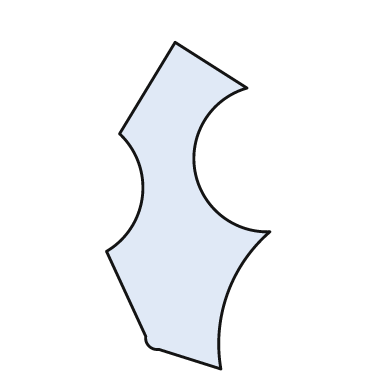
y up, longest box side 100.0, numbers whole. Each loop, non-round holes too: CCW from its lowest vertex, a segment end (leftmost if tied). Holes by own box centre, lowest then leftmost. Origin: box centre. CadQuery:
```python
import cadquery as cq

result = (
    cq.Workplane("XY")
    .moveTo(10.0, -50.0)
    .threePointArc((12.0, -27.0), (25.0, -8.0))
    .threePointArc((2.0, 11.0), (18.0, 36.0))
    .lineTo(-4.0, 50.0)
    .lineTo(-21.0, 22.0)
    .threePointArc((-14.0, 3.0), (-25.0, -14.0))
    .lineTo(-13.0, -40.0)
    .threePointArc((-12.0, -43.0), (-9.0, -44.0))
    .close()
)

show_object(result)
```